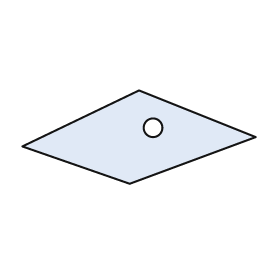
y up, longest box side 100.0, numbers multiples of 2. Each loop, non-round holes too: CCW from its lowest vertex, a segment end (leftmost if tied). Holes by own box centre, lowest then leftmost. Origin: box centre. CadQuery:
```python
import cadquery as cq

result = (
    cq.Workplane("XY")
    .moveTo(-4.0, -20.0)
    .lineTo(50.0, 0.0)
    .lineTo(0.0, 20.0)
    .lineTo(-50.0, -4.0)
    .close()
    .moveTo(6.0, 4.0)
    .circle(4.0)
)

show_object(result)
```